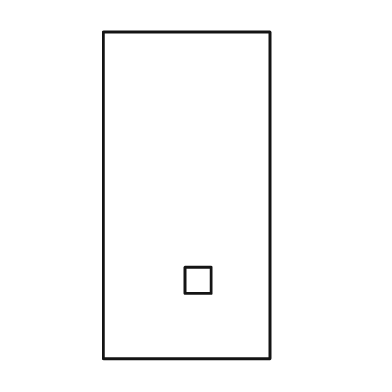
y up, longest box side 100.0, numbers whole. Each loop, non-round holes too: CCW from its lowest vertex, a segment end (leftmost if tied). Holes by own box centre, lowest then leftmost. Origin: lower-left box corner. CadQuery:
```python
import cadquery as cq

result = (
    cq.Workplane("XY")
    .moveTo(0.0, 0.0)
    .lineTo(51.0, 0.0)
    .lineTo(51.0, 100.0)
    .lineTo(0.0, 100.0)
    .close()
    .moveTo(25.0, 20.0)
    .lineTo(33.0, 20.0)
    .lineTo(33.0, 28.0)
    .lineTo(25.0, 28.0)
    .close()
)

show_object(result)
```